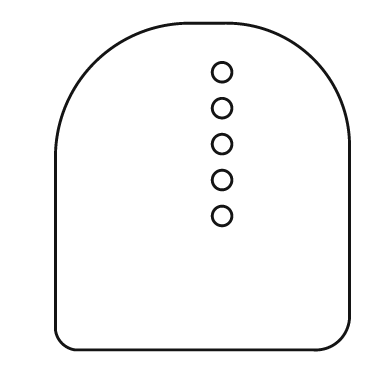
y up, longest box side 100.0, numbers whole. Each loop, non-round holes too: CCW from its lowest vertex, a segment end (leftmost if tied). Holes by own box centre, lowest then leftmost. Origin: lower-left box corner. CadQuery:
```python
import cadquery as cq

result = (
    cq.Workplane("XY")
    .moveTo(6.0, 0.0)
    .lineTo(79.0, 0.0)
    .threePointArc((87.0, 3.0), (90.0, 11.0))
    .lineTo(90.0, 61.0)
    .threePointArc((79.0, 89.0), (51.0, 100.0))
    .lineTo(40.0, 100.0)
    .threePointArc((12.0, 88.0), (0.0, 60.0))
    .lineTo(0.0, 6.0)
    .threePointArc((2.0, 2.0), (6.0, 0.0))
    .close()
    .moveTo(51.0, 41.0)
    .circle(3.0)
    .moveTo(51.0, 52.0)
    .circle(3.0)
    .moveTo(51.0, 63.0)
    .circle(3.0)
    .moveTo(51.0, 74.0)
    .circle(3.0)
    .moveTo(51.0, 85.0)
    .circle(3.0)
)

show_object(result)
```